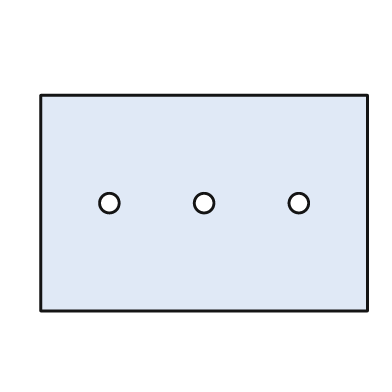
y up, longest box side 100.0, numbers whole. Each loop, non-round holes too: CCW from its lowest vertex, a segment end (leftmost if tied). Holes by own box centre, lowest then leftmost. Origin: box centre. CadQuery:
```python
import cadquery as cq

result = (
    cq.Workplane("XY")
    .moveTo(-50.0, -33.0)
    .lineTo(50.0, -33.0)
    .lineTo(50.0, 33.0)
    .lineTo(-50.0, 33.0)
    .close()
    .moveTo(-29.0, 0.0)
    .circle(3.0)
    .moveTo(0.0, 0.0)
    .circle(3.0)
    .moveTo(29.0, 0.0)
    .circle(3.0)
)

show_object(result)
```